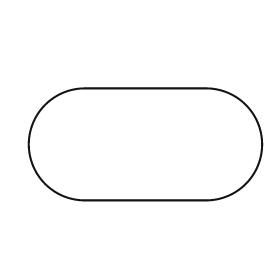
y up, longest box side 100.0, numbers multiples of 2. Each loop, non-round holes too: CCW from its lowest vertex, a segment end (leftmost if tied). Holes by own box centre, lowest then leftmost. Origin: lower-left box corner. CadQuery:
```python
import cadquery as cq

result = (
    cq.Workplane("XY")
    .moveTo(24.0, 0.0)
    .lineTo(76.0, 0.0)
    .threePointArc((100.0, 24.0), (76.0, 48.0))
    .lineTo(24.0, 48.0)
    .threePointArc((0.0, 24.0), (24.0, 0.0))
    .close()
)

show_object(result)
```